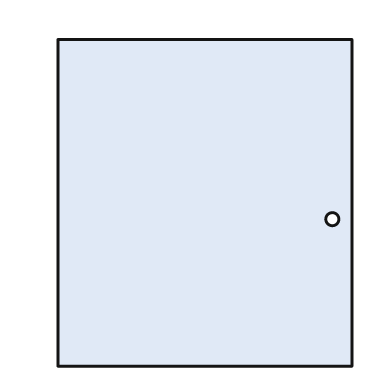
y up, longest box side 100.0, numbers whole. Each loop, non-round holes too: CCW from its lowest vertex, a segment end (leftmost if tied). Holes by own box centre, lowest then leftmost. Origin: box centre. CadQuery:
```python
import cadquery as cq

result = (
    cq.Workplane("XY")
    .moveTo(-45.0, -50.0)
    .lineTo(45.0, -50.0)
    .lineTo(45.0, 50.0)
    .lineTo(-45.0, 50.0)
    .close()
    .moveTo(39.0, -5.0)
    .circle(2.0)
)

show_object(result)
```